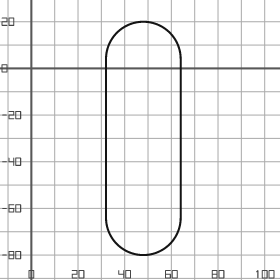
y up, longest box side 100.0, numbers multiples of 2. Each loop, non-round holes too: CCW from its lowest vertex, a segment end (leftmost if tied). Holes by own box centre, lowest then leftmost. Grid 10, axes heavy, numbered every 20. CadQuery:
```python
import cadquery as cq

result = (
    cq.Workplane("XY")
    .moveTo(32.0, -64.0)
    .threePointArc((48.0, -80.0), (64.0, -64.0))
    .lineTo(64.0, 4.0)
    .threePointArc((48.0, 20.0), (32.0, 4.0))
    .close()
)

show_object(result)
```